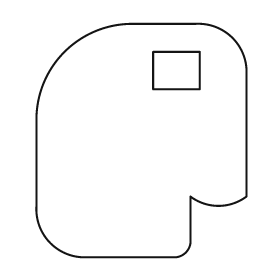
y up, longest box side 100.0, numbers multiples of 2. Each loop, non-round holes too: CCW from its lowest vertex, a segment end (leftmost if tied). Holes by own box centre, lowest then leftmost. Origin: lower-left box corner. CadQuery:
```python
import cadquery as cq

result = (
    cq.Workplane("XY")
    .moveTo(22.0, 0.0)
    .lineTo(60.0, 0.0)
    .threePointArc((64.0, 2.0), (66.0, 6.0))
    .lineTo(66.0, 26.0)
    .threePointArc((78.0, 22.0), (90.0, 26.0))
    .lineTo(90.0, 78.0)
    .threePointArc((84.0, 94.0), (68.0, 100.0))
    .lineTo(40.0, 100.0)
    .threePointArc((12.0, 88.0), (0.0, 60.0))
    .lineTo(0.0, 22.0)
    .threePointArc((6.0, 6.0), (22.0, 0.0))
    .close()
    .moveTo(50.0, 72.0)
    .lineTo(70.0, 72.0)
    .lineTo(70.0, 88.0)
    .lineTo(50.0, 88.0)
    .close()
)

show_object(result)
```